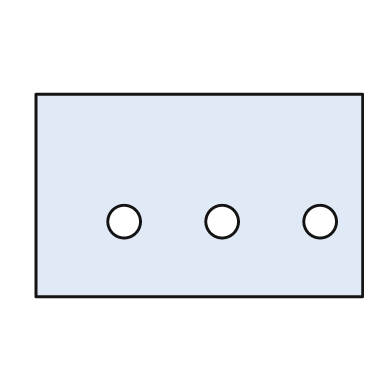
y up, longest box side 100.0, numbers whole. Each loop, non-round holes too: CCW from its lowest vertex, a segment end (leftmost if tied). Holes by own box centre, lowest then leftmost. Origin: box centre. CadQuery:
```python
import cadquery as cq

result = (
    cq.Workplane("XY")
    .moveTo(-50.0, -31.0)
    .lineTo(50.0, -31.0)
    .lineTo(50.0, 31.0)
    .lineTo(-50.0, 31.0)
    .close()
    .moveTo(-23.0, -8.0)
    .circle(5.0)
    .moveTo(7.0, -8.0)
    .circle(5.0)
    .moveTo(37.0, -8.0)
    .circle(5.0)
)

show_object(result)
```